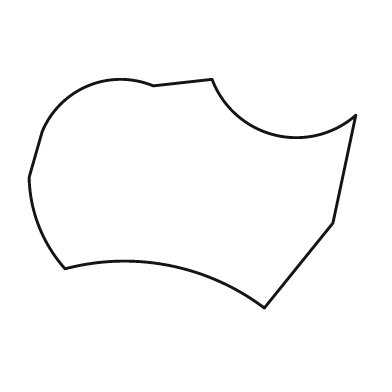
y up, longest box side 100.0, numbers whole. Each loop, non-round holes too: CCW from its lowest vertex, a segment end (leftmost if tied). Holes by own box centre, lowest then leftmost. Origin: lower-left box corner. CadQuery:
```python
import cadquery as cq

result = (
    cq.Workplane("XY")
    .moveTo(72.0, 0.0)
    .lineTo(93.0, 26.0)
    .lineTo(100.0, 59.0)
    .threePointArc((75.0, 53.0), (56.0, 70.0))
    .lineTo(38.0, 68.0)
    .threePointArc((18.0, 68.0), (4.0, 54.0))
    .lineTo(0.0, 40.0)
    .threePointArc((3.0, 25.0), (11.0, 12.0))
    .threePointArc((43.0, 13.0), (72.0, 0.0))
    .close()
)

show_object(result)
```